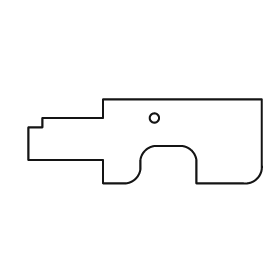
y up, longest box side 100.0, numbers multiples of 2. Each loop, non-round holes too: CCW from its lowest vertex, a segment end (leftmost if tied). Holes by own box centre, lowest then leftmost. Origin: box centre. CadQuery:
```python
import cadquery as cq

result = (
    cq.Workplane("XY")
    .moveTo(-18.0, -18.0)
    .lineTo(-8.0, -18.0)
    .threePointArc((-4.0, -16.0), (-2.0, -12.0))
    .lineTo(-2.0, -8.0)
    .threePointArc((0.0, -4.0), (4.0, -2.0))
    .lineTo(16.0, -2.0)
    .threePointArc((20.0, -4.0), (22.0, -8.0))
    .lineTo(22.0, -18.0)
    .lineTo(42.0, -18.0)
    .threePointArc((48.0, -16.0), (50.0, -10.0))
    .lineTo(50.0, 18.0)
    .lineTo(-18.0, 18.0)
    .lineTo(-18.0, 10.0)
    .lineTo(-44.0, 10.0)
    .lineTo(-44.0, 6.0)
    .lineTo(-50.0, 6.0)
    .lineTo(-50.0, -8.0)
    .lineTo(-18.0, -8.0)
    .close()
    .moveTo(4.0, 10.0)
    .circle(2.0)
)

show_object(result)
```